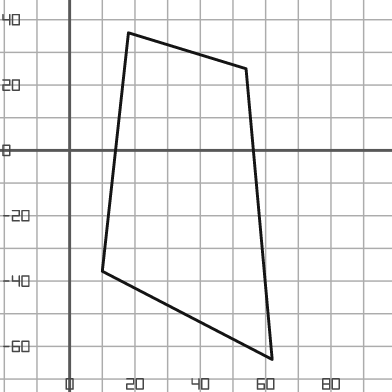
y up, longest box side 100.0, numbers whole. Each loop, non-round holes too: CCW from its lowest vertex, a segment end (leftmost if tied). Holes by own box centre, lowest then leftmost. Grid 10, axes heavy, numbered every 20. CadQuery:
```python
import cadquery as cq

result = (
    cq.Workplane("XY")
    .moveTo(62.0, -64.0)
    .lineTo(54.0, 25.0)
    .lineTo(18.0, 36.0)
    .lineTo(10.0, -37.0)
    .close()
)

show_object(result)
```